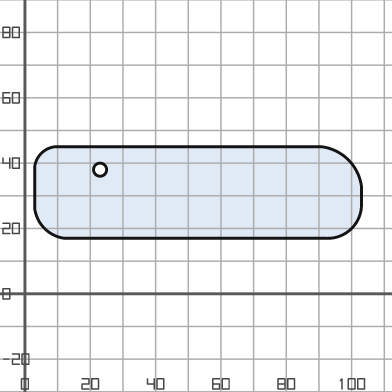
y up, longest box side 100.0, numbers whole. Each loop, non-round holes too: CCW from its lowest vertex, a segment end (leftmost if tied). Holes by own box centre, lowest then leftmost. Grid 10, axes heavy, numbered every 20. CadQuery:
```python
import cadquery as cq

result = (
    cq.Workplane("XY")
    .moveTo(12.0, 17.0)
    .lineTo(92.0, 17.0)
    .threePointArc((100.0, 20.0), (103.0, 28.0))
    .lineTo(103.0, 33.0)
    .threePointArc((99.0, 41.0), (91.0, 45.0))
    .lineTo(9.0, 45.0)
    .threePointArc((5.0, 43.0), (3.0, 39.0))
    .lineTo(3.0, 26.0)
    .threePointArc((6.0, 20.0), (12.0, 17.0))
    .close()
    .moveTo(23.0, 38.0)
    .circle(2.0)
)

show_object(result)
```